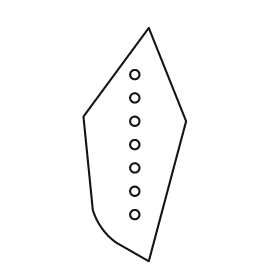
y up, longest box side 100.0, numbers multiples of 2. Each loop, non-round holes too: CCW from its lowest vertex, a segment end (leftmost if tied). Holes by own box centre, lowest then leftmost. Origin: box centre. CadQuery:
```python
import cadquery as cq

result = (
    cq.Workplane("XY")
    .moveTo(6.0, -50.0)
    .lineTo(22.0, 10.0)
    .lineTo(6.0, 50.0)
    .lineTo(-22.0, 12.0)
    .lineTo(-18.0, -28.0)
    .threePointArc((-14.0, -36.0), (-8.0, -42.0))
    .close()
    .moveTo(0.0, -30.0)
    .circle(2.0)
    .moveTo(0.0, -20.0)
    .circle(2.0)
    .moveTo(0.0, -10.0)
    .circle(2.0)
    .moveTo(0.0, 0.0)
    .circle(2.0)
    .moveTo(0.0, 10.0)
    .circle(2.0)
    .moveTo(0.0, 20.0)
    .circle(2.0)
    .moveTo(0.0, 30.0)
    .circle(2.0)
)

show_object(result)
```